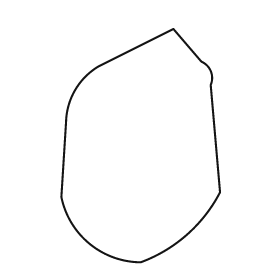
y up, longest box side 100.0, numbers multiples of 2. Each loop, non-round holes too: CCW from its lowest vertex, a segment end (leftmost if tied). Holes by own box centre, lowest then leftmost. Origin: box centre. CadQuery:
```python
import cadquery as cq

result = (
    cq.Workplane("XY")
    .moveTo(0.0, -50.0)
    .threePointArc((20.0, -38.0), (34.0, -20.0))
    .lineTo(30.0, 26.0)
    .threePointArc((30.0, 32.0), (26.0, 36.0))
    .lineTo(14.0, 50.0)
    .lineTo(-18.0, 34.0)
    .threePointArc((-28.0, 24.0), (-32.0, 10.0))
    .lineTo(-34.0, -22.0)
    .threePointArc((-22.0, -42.0), (0.0, -50.0))
    .close()
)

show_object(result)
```